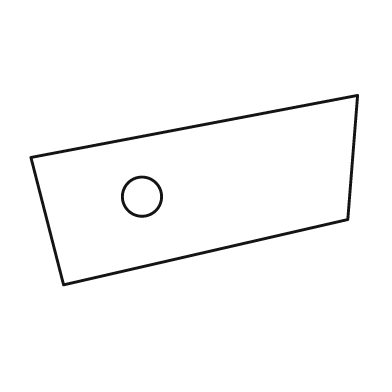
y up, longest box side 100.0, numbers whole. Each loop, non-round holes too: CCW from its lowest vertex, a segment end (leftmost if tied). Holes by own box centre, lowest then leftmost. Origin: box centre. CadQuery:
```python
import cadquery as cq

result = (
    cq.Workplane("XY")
    .moveTo(-40.0, -29.0)
    .lineTo(47.0, -9.0)
    .lineTo(50.0, 29.0)
    .lineTo(-50.0, 10.0)
    .close()
    .moveTo(-16.0, -2.0)
    .circle(6.0)
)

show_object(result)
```